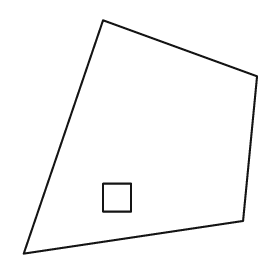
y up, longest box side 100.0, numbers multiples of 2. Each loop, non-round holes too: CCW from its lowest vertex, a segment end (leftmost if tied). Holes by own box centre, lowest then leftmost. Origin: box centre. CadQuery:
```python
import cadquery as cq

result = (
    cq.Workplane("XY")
    .moveTo(-50.0, -50.0)
    .lineTo(44.0, -36.0)
    .lineTo(50.0, 26.0)
    .lineTo(-16.0, 50.0)
    .close()
    .moveTo(-16.0, -32.0)
    .lineTo(-4.0, -32.0)
    .lineTo(-4.0, -20.0)
    .lineTo(-16.0, -20.0)
    .close()
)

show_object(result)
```